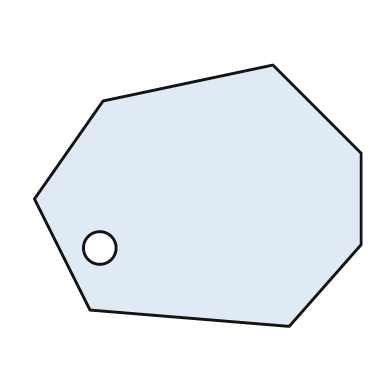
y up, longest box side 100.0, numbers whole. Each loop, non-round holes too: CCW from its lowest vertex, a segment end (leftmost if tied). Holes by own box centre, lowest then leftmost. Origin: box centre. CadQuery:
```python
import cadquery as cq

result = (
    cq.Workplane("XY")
    .moveTo(28.0, -40.0)
    .lineTo(50.0, -15.0)
    .lineTo(50.0, 13.0)
    .lineTo(23.0, 40.0)
    .lineTo(-29.0, 29.0)
    .lineTo(-50.0, -1.0)
    .lineTo(-33.0, -35.0)
    .close()
    .moveTo(-30.0, -16.0)
    .circle(5.0)
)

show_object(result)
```